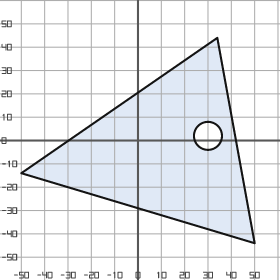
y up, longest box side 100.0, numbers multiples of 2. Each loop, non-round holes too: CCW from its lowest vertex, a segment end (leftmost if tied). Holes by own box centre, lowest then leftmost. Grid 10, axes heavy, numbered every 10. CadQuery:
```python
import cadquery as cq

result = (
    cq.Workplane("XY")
    .moveTo(50.0, -44.0)
    .lineTo(34.0, 44.0)
    .lineTo(-50.0, -14.0)
    .close()
    .moveTo(30.0, 2.0)
    .circle(6.0)
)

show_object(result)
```